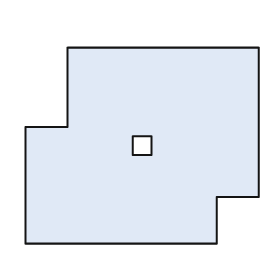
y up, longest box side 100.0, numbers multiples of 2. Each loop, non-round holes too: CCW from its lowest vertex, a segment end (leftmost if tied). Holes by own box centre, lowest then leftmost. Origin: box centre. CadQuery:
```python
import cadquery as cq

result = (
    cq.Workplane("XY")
    .moveTo(-50.0, -42.0)
    .lineTo(32.0, -42.0)
    .lineTo(32.0, -22.0)
    .lineTo(50.0, -22.0)
    .lineTo(50.0, 42.0)
    .lineTo(-32.0, 42.0)
    .lineTo(-32.0, 8.0)
    .lineTo(-50.0, 8.0)
    .close()
    .moveTo(-4.0, -4.0)
    .lineTo(4.0, -4.0)
    .lineTo(4.0, 4.0)
    .lineTo(-4.0, 4.0)
    .close()
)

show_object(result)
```